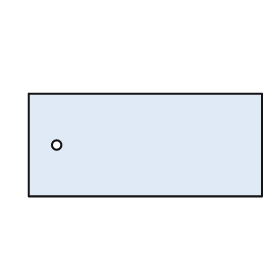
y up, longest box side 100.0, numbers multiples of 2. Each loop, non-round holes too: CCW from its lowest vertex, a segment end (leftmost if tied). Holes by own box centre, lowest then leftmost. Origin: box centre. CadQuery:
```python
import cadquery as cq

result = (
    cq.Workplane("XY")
    .moveTo(-50.0, -22.0)
    .lineTo(50.0, -22.0)
    .lineTo(50.0, 22.0)
    .lineTo(-50.0, 22.0)
    .close()
    .moveTo(-38.0, 0.0)
    .circle(2.0)
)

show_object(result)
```